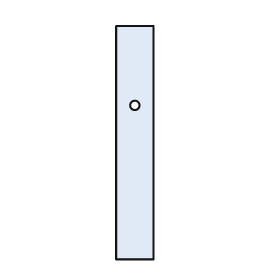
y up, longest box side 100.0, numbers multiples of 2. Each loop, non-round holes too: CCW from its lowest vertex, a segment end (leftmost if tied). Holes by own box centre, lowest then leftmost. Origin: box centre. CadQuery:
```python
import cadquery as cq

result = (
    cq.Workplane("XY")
    .moveTo(-8.0, -50.0)
    .lineTo(8.0, -50.0)
    .lineTo(8.0, 50.0)
    .lineTo(-8.0, 50.0)
    .close()
    .moveTo(0.0, 16.0)
    .circle(2.0)
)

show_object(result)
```